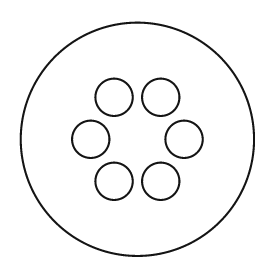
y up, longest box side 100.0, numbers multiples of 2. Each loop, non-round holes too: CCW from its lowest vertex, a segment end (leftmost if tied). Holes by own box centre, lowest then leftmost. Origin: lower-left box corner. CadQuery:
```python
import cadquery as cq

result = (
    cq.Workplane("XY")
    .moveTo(50.0, 50.0)
    .circle(50.0)
    .moveTo(40.0, 32.0)
    .circle(8.0)
    .moveTo(60.0, 32.0)
    .circle(8.0)
    .moveTo(30.0, 50.0)
    .circle(8.0)
    .moveTo(70.0, 50.0)
    .circle(8.0)
    .moveTo(40.0, 68.0)
    .circle(8.0)
    .moveTo(60.0, 68.0)
    .circle(8.0)
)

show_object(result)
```